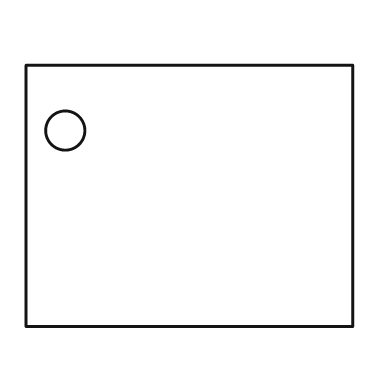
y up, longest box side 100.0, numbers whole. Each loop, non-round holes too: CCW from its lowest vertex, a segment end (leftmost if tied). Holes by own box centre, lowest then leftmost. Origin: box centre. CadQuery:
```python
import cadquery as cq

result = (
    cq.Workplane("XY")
    .moveTo(-50.0, -40.0)
    .lineTo(50.0, -40.0)
    .lineTo(50.0, 40.0)
    .lineTo(-50.0, 40.0)
    .close()
    .moveTo(-38.0, 20.0)
    .circle(6.0)
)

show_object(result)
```